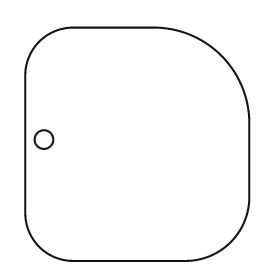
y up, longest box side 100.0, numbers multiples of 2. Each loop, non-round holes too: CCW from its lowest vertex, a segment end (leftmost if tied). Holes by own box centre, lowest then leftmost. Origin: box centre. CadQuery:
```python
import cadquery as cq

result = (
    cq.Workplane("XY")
    .moveTo(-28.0, -50.0)
    .lineTo(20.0, -50.0)
    .threePointArc((40.0, -42.0), (48.0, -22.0))
    .lineTo(48.0, 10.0)
    .threePointArc((36.0, 38.0), (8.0, 50.0))
    .lineTo(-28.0, 50.0)
    .threePointArc((-42.0, 44.0), (-48.0, 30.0))
    .lineTo(-48.0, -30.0)
    .threePointArc((-42.0, -44.0), (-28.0, -50.0))
    .close()
    .moveTo(-40.0, 2.0)
    .circle(4.0)
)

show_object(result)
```